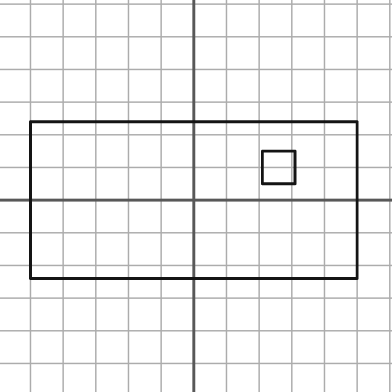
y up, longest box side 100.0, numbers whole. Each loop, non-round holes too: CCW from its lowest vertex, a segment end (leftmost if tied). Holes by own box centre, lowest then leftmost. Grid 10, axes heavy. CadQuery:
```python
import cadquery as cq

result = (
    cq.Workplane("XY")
    .moveTo(-50.0, -24.0)
    .lineTo(50.0, -24.0)
    .lineTo(50.0, 24.0)
    .lineTo(-50.0, 24.0)
    .close()
    .moveTo(21.0, 5.0)
    .lineTo(31.0, 5.0)
    .lineTo(31.0, 15.0)
    .lineTo(21.0, 15.0)
    .close()
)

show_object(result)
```